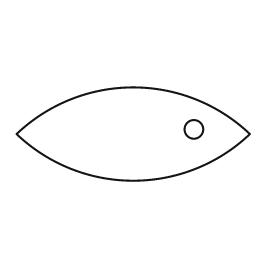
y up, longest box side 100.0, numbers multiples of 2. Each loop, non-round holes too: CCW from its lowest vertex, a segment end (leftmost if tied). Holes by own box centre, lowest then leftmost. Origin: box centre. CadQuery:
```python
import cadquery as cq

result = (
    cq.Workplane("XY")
    .moveTo(-50.0, 0.0)
    .threePointArc((0.0, -20.0), (50.0, 0.0))
    .threePointArc((0.0, 20.0), (-50.0, 0.0))
    .close()
    .moveTo(26.0, 2.0)
    .circle(4.0)
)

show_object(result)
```